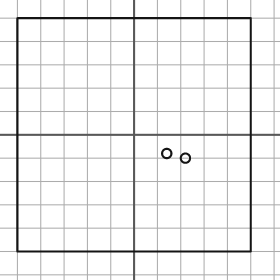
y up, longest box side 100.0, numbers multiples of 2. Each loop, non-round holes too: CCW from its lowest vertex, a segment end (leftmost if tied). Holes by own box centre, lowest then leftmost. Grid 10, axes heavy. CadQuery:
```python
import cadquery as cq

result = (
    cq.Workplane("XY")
    .moveTo(-50.0, -50.0)
    .lineTo(50.0, -50.0)
    .lineTo(50.0, 50.0)
    .lineTo(-50.0, 50.0)
    .close()
    .moveTo(22.0, -10.0)
    .circle(2.0)
    .moveTo(14.0, -8.0)
    .circle(2.0)
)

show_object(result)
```